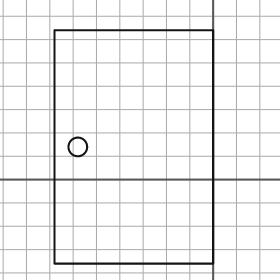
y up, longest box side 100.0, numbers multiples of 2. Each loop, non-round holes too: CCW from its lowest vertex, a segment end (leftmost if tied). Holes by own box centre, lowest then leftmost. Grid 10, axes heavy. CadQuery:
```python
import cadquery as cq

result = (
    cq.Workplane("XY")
    .moveTo(-68.0, -36.0)
    .lineTo(0.0, -36.0)
    .lineTo(0.0, 64.0)
    .lineTo(-68.0, 64.0)
    .close()
    .moveTo(-58.0, 14.0)
    .circle(4.0)
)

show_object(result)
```